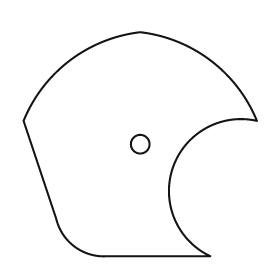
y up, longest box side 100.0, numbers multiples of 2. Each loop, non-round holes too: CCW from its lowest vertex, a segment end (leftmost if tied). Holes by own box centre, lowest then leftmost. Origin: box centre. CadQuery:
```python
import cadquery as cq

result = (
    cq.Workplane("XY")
    .moveTo(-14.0, -48.0)
    .lineTo(30.0, -48.0)
    .threePointArc((14.0, -10.0), (50.0, 10.0))
    .threePointArc((30.0, 36.0), (0.0, 48.0))
    .threePointArc((-30.0, 36.0), (-50.0, 10.0))
    .lineTo(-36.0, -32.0)
    .threePointArc((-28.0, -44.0), (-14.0, -48.0))
    .close()
    .moveTo(0.0, 0.0)
    .circle(4.0)
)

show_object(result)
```